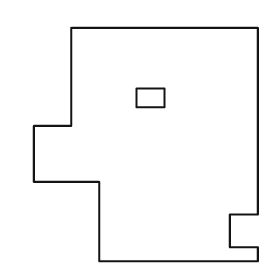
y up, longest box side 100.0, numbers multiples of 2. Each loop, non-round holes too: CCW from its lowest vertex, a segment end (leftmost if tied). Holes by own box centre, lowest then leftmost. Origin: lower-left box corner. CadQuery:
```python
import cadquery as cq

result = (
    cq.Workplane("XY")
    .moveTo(28.0, 0.0)
    .lineTo(96.0, 0.0)
    .lineTo(96.0, 6.0)
    .lineTo(84.0, 6.0)
    .lineTo(84.0, 20.0)
    .lineTo(96.0, 20.0)
    .lineTo(96.0, 100.0)
    .lineTo(16.0, 100.0)
    .lineTo(16.0, 58.0)
    .lineTo(0.0, 58.0)
    .lineTo(0.0, 34.0)
    .lineTo(28.0, 34.0)
    .close()
    .moveTo(44.0, 66.0)
    .lineTo(56.0, 66.0)
    .lineTo(56.0, 74.0)
    .lineTo(44.0, 74.0)
    .close()
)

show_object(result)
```